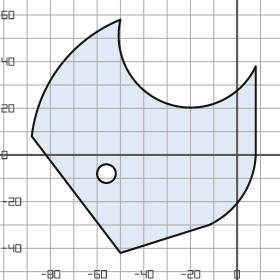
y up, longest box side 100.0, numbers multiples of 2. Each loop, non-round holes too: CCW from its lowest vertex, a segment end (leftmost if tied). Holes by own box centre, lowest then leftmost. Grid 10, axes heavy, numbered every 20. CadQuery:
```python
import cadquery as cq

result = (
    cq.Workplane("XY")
    .moveTo(-50.0, -42.0)
    .lineTo(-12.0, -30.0)
    .threePointArc((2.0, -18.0), (8.0, 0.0))
    .lineTo(8.0, 38.0)
    .threePointArc((-30.0, 22.0), (-50.0, 58.0))
    .threePointArc((-76.0, 38.0), (-88.0, 8.0))
    .close()
    .moveTo(-56.0, -8.0)
    .circle(4.0)
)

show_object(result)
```